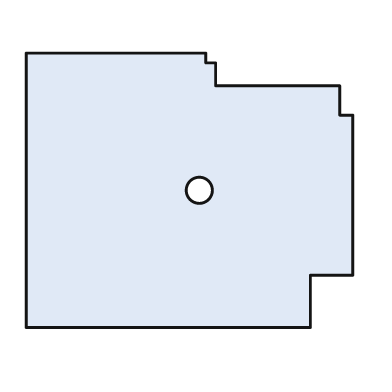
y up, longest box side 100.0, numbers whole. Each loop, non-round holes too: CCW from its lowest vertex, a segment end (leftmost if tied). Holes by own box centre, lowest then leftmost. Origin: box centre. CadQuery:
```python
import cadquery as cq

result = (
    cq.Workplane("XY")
    .moveTo(-50.0, -42.0)
    .lineTo(37.0, -42.0)
    .lineTo(37.0, -26.0)
    .lineTo(50.0, -26.0)
    .lineTo(50.0, 23.0)
    .lineTo(46.0, 23.0)
    .lineTo(46.0, 32.0)
    .lineTo(8.0, 32.0)
    .lineTo(8.0, 39.0)
    .lineTo(5.0, 39.0)
    .lineTo(5.0, 42.0)
    .lineTo(-50.0, 42.0)
    .close()
    .moveTo(3.0, 0.0)
    .circle(4.0)
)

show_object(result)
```